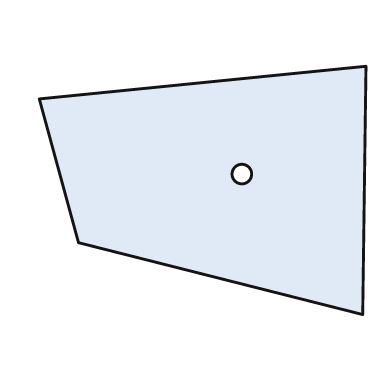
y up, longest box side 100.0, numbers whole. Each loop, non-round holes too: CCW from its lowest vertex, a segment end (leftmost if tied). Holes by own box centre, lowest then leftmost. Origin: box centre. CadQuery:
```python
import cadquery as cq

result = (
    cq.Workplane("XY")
    .moveTo(49.0, -38.0)
    .lineTo(50.0, 38.0)
    .lineTo(-50.0, 28.0)
    .lineTo(-38.0, -16.0)
    .close()
    .moveTo(12.0, 5.0)
    .circle(3.0)
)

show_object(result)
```